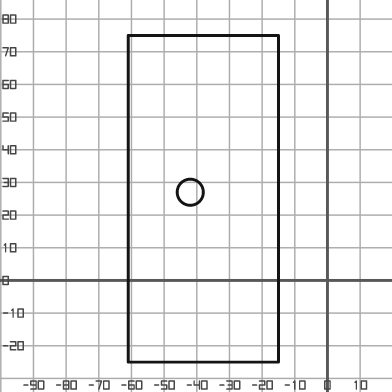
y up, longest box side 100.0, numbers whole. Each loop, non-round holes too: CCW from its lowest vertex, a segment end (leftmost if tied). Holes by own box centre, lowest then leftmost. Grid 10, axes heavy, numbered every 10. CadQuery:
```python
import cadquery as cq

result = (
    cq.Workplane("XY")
    .moveTo(-61.0, -25.0)
    .lineTo(-15.0, -25.0)
    .lineTo(-15.0, 75.0)
    .lineTo(-61.0, 75.0)
    .close()
    .moveTo(-42.0, 27.0)
    .circle(4.0)
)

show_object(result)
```